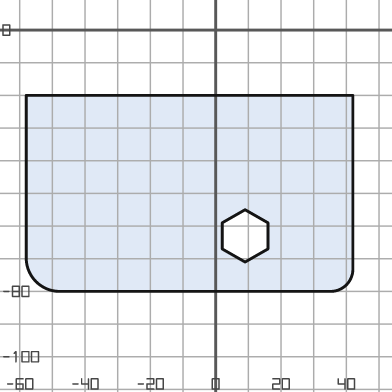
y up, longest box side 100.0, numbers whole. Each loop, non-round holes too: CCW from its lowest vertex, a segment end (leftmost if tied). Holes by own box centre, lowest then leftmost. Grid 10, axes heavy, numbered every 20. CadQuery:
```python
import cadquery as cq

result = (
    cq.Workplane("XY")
    .moveTo(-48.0, -80.0)
    .lineTo(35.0, -80.0)
    .threePointArc((40.0, -78.0), (42.0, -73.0))
    .lineTo(42.0, -20.0)
    .lineTo(-58.0, -20.0)
    .lineTo(-58.0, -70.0)
    .threePointArc((-55.0, -77.0), (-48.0, -80.0))
    .close()
    .moveTo(9.0, -71.0)
    .lineTo(16.0, -67.0)
    .lineTo(16.0, -59.0)
    .lineTo(9.0, -55.0)
    .lineTo(2.0, -59.0)
    .lineTo(2.0, -67.0)
    .close()
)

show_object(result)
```